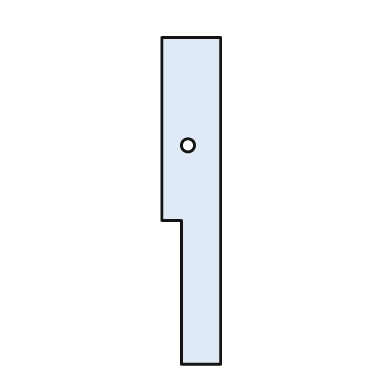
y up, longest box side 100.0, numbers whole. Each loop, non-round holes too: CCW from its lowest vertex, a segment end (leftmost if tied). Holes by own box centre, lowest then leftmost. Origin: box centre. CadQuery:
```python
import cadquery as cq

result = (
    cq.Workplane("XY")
    .moveTo(-3.0, -50.0)
    .lineTo(9.0, -50.0)
    .lineTo(9.0, 50.0)
    .lineTo(-9.0, 50.0)
    .lineTo(-9.0, -6.0)
    .lineTo(-3.0, -6.0)
    .close()
    .moveTo(-1.0, 17.0)
    .circle(2.0)
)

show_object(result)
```